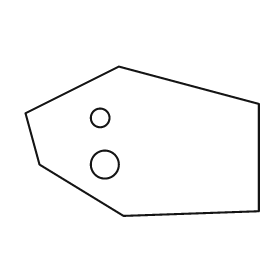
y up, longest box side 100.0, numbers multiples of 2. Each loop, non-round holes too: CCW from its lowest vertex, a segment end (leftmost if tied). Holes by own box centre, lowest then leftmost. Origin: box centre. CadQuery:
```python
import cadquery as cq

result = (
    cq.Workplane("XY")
    .moveTo(-8.0, -32.0)
    .lineTo(50.0, -30.0)
    .lineTo(50.0, 16.0)
    .lineTo(-10.0, 32.0)
    .lineTo(-50.0, 12.0)
    .lineTo(-44.0, -10.0)
    .close()
    .moveTo(-16.0, -10.0)
    .circle(6.0)
    .moveTo(-18.0, 10.0)
    .circle(4.0)
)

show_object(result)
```